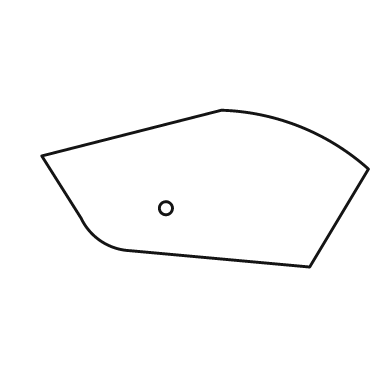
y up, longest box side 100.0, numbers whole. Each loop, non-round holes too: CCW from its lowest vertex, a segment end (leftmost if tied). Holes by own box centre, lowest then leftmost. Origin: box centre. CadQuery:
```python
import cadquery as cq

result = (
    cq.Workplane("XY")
    .moveTo(32.0, -24.0)
    .lineTo(50.0, 6.0)
    .threePointArc((29.0, 19.0), (5.0, 24.0))
    .lineTo(-50.0, 10.0)
    .lineTo(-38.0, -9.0)
    .threePointArc((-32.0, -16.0), (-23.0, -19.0))
    .close()
    .moveTo(-12.0, -6.0)
    .circle(2.0)
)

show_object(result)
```